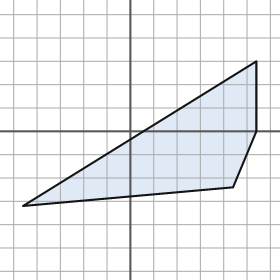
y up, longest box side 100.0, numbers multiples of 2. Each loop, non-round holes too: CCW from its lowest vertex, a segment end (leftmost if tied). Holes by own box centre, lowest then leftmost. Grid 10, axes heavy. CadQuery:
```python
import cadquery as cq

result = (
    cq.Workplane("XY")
    .moveTo(-46.0, -32.0)
    .lineTo(44.0, -24.0)
    .lineTo(54.0, 0.0)
    .lineTo(54.0, 30.0)
    .close()
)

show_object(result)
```